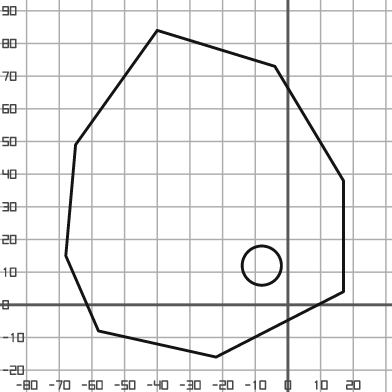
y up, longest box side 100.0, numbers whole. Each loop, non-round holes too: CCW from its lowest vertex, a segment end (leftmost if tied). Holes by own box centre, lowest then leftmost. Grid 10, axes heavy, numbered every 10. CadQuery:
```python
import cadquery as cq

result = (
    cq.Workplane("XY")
    .moveTo(-22.0, -16.0)
    .lineTo(17.0, 4.0)
    .lineTo(17.0, 38.0)
    .lineTo(-4.0, 73.0)
    .lineTo(-40.0, 84.0)
    .lineTo(-65.0, 49.0)
    .lineTo(-68.0, 15.0)
    .lineTo(-58.0, -8.0)
    .close()
    .moveTo(-8.0, 12.0)
    .circle(6.0)
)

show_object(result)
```